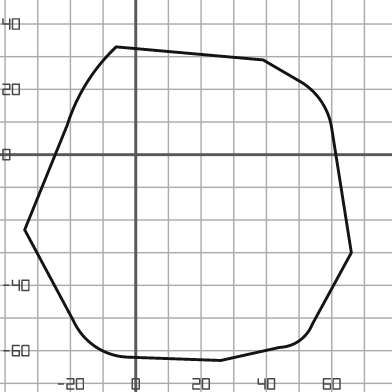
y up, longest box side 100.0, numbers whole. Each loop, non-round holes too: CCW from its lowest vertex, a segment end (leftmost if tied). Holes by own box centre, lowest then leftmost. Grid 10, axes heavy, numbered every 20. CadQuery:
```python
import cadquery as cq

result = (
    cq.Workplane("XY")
    .moveTo(26.0, -63.0)
    .lineTo(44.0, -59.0)
    .threePointArc((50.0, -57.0), (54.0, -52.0))
    .lineTo(66.0, -30.0)
    .lineTo(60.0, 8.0)
    .threePointArc((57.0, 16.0), (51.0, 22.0))
    .lineTo(39.0, 29.0)
    .lineTo(-6.0, 33.0)
    .threePointArc((-15.0, 22.0), (-21.0, 9.0))
    .lineTo(-34.0, -23.0)
    .lineTo(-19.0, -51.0)
    .threePointArc((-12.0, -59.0), (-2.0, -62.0))
    .close()
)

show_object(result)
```